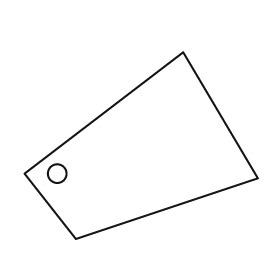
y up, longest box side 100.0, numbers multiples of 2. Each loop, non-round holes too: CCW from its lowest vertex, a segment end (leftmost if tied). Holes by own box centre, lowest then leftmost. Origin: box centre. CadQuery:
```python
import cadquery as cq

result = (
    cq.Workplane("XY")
    .moveTo(-28.0, -40.0)
    .lineTo(50.0, -14.0)
    .lineTo(18.0, 40.0)
    .lineTo(-50.0, -12.0)
    .close()
    .moveTo(-36.0, -12.0)
    .circle(4.0)
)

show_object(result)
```